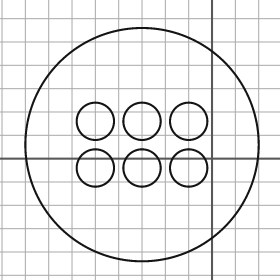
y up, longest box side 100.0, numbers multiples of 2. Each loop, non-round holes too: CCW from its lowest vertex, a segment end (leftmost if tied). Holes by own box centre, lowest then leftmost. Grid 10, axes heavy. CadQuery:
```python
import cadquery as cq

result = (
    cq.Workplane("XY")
    .moveTo(-30.0, 6.0)
    .circle(50.0)
    .moveTo(-50.0, -4.0)
    .circle(8.0)
    .moveTo(-30.0, -4.0)
    .circle(8.0)
    .moveTo(-10.0, -4.0)
    .circle(8.0)
    .moveTo(-50.0, 16.0)
    .circle(8.0)
    .moveTo(-30.0, 16.0)
    .circle(8.0)
    .moveTo(-10.0, 16.0)
    .circle(8.0)
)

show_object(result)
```